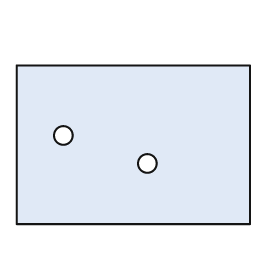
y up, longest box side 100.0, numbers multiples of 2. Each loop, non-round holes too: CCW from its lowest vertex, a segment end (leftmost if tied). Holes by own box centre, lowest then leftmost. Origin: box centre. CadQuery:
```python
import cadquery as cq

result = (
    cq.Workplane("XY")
    .moveTo(-50.0, -34.0)
    .lineTo(50.0, -34.0)
    .lineTo(50.0, 34.0)
    .lineTo(-50.0, 34.0)
    .close()
    .moveTo(6.0, -8.0)
    .circle(4.0)
    .moveTo(-30.0, 4.0)
    .circle(4.0)
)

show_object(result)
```